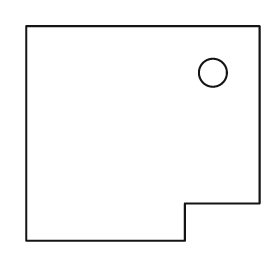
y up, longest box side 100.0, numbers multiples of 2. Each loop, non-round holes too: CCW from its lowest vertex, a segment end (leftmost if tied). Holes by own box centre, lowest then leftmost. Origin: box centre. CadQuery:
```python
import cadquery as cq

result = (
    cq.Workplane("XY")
    .moveTo(-50.0, -46.0)
    .lineTo(18.0, -46.0)
    .lineTo(18.0, -30.0)
    .lineTo(50.0, -30.0)
    .lineTo(50.0, 46.0)
    .lineTo(-50.0, 46.0)
    .close()
    .moveTo(30.0, 26.0)
    .circle(6.0)
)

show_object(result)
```